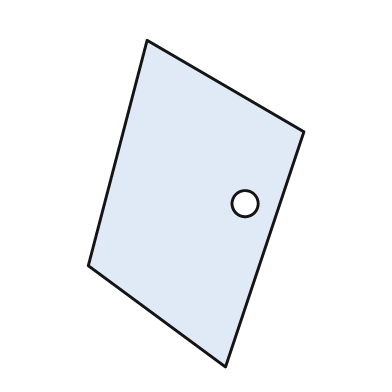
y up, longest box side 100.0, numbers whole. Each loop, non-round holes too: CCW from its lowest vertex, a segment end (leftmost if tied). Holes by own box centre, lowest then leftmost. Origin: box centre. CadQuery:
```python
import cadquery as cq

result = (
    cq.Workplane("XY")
    .moveTo(9.0, -50.0)
    .lineTo(33.0, 22.0)
    .lineTo(-15.0, 50.0)
    .lineTo(-33.0, -19.0)
    .close()
    .moveTo(15.0, 0.0)
    .circle(4.0)
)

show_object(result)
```